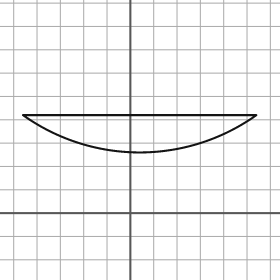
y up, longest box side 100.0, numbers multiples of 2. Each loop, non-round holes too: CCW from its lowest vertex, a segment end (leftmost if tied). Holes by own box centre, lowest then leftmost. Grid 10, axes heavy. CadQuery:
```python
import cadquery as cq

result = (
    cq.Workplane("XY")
    .moveTo(-46.0, 42.0)
    .threePointArc((4.0, 26.0), (54.0, 42.0))
    .close()
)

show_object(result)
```